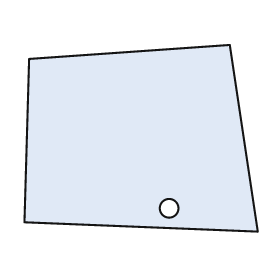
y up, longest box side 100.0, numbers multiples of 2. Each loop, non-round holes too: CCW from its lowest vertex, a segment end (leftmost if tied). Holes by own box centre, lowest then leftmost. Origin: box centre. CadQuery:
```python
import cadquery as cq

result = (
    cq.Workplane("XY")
    .moveTo(50.0, -40.0)
    .lineTo(38.0, 40.0)
    .lineTo(-48.0, 34.0)
    .lineTo(-50.0, -36.0)
    .close()
    .moveTo(12.0, -30.0)
    .circle(4.0)
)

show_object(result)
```